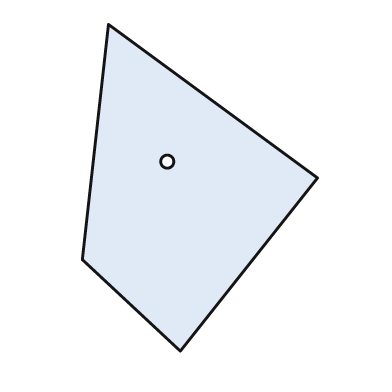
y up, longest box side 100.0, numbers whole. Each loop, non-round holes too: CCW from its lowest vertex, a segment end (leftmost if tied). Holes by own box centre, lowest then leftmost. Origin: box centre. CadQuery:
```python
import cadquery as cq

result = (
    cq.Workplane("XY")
    .moveTo(-6.0, -50.0)
    .lineTo(36.0, 3.0)
    .lineTo(-28.0, 50.0)
    .lineTo(-36.0, -22.0)
    .close()
    .moveTo(-10.0, 8.0)
    .circle(2.0)
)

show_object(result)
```